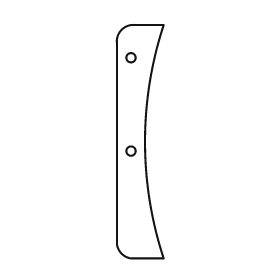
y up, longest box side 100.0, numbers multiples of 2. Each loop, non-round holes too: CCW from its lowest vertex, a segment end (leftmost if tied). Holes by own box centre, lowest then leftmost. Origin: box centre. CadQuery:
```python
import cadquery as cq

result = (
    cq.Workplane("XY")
    .moveTo(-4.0, -50.0)
    .lineTo(10.0, -50.0)
    .threePointArc((2.0, 0.0), (10.0, 50.0))
    .lineTo(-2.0, 50.0)
    .threePointArc((-8.0, 48.0), (-10.0, 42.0))
    .lineTo(-10.0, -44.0)
    .threePointArc((-8.0, -48.0), (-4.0, -50.0))
    .close()
    .moveTo(-4.0, -4.0)
    .circle(2.0)
    .moveTo(-4.0, 36.0)
    .circle(2.0)
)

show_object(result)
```